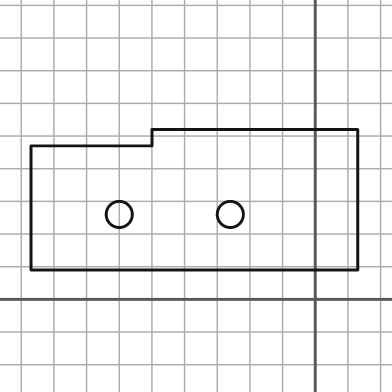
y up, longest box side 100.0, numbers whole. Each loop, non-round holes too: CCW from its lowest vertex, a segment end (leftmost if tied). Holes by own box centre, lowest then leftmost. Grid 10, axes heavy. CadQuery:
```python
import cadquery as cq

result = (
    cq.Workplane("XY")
    .moveTo(-87.0, 9.0)
    .lineTo(13.0, 9.0)
    .lineTo(13.0, 52.0)
    .lineTo(-50.0, 52.0)
    .lineTo(-50.0, 47.0)
    .lineTo(-87.0, 47.0)
    .close()
    .moveTo(-60.0, 26.0)
    .circle(4.0)
    .moveTo(-26.0, 26.0)
    .circle(4.0)
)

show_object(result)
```